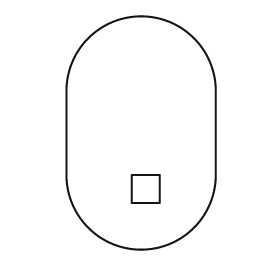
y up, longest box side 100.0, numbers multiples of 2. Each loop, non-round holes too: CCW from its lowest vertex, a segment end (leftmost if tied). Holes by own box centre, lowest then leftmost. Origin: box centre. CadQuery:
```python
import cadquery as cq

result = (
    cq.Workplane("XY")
    .moveTo(-32.0, -18.0)
    .threePointArc((0.0, -50.0), (32.0, -18.0))
    .lineTo(32.0, 18.0)
    .threePointArc((0.0, 50.0), (-32.0, 18.0))
    .close()
    .moveTo(-4.0, -30.0)
    .lineTo(8.0, -30.0)
    .lineTo(8.0, -18.0)
    .lineTo(-4.0, -18.0)
    .close()
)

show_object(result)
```